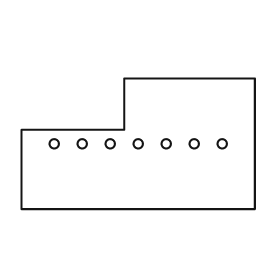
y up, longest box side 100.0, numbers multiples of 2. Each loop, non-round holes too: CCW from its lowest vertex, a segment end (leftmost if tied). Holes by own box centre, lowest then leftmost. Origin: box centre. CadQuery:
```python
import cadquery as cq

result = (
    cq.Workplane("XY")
    .moveTo(-50.0, -28.0)
    .lineTo(50.0, -28.0)
    .lineTo(50.0, 28.0)
    .lineTo(-6.0, 28.0)
    .lineTo(-6.0, 6.0)
    .lineTo(-50.0, 6.0)
    .close()
    .moveTo(-36.0, 0.0)
    .circle(2.0)
    .moveTo(-24.0, 0.0)
    .circle(2.0)
    .moveTo(-12.0, 0.0)
    .circle(2.0)
    .moveTo(0.0, 0.0)
    .circle(2.0)
    .moveTo(12.0, 0.0)
    .circle(2.0)
    .moveTo(24.0, 0.0)
    .circle(2.0)
    .moveTo(36.0, 0.0)
    .circle(2.0)
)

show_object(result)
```